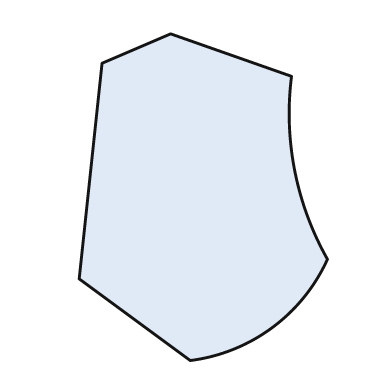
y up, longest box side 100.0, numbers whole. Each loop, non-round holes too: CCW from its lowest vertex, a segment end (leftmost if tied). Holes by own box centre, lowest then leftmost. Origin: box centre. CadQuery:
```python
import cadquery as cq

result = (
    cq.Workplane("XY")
    .moveTo(-4.0, -50.0)
    .threePointArc((21.0, -40.0), (38.0, -19.0))
    .threePointArc((28.0, 8.0), (27.0, 37.0))
    .lineTo(-10.0, 50.0)
    .lineTo(-31.0, 41.0)
    .lineTo(-38.0, -25.0)
    .close()
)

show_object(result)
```